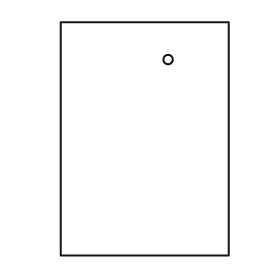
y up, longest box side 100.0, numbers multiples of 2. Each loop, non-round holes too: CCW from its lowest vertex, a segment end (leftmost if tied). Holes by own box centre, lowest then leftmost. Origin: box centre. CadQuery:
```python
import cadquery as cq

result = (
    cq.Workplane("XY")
    .moveTo(-36.0, -50.0)
    .lineTo(36.0, -50.0)
    .lineTo(36.0, 50.0)
    .lineTo(-36.0, 50.0)
    .close()
    .moveTo(10.0, 34.0)
    .circle(2.0)
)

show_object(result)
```